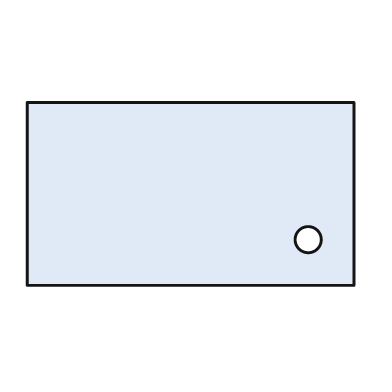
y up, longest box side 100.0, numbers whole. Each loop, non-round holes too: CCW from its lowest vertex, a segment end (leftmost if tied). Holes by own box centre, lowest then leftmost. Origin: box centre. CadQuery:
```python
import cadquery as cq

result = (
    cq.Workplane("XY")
    .moveTo(-50.0, -28.0)
    .lineTo(50.0, -28.0)
    .lineTo(50.0, 28.0)
    .lineTo(-50.0, 28.0)
    .close()
    .moveTo(36.0, -14.0)
    .circle(4.0)
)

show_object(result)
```